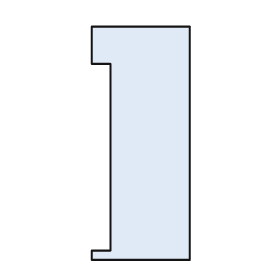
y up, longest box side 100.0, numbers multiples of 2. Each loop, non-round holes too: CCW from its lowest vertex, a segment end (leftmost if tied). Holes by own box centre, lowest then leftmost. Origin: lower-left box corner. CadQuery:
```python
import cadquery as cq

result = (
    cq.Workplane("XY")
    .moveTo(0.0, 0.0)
    .lineTo(42.0, 0.0)
    .lineTo(42.0, 100.0)
    .lineTo(0.0, 100.0)
    .lineTo(0.0, 84.0)
    .lineTo(8.0, 84.0)
    .lineTo(8.0, 4.0)
    .lineTo(0.0, 4.0)
    .close()
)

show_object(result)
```